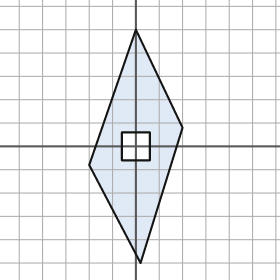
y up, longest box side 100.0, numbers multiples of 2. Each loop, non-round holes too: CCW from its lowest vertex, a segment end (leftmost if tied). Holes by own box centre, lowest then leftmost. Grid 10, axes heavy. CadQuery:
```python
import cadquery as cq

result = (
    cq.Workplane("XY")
    .moveTo(2.0, -50.0)
    .lineTo(20.0, 8.0)
    .lineTo(0.0, 50.0)
    .lineTo(-20.0, -8.0)
    .close()
    .moveTo(-6.0, -6.0)
    .lineTo(6.0, -6.0)
    .lineTo(6.0, 6.0)
    .lineTo(-6.0, 6.0)
    .close()
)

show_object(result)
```